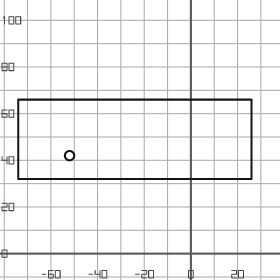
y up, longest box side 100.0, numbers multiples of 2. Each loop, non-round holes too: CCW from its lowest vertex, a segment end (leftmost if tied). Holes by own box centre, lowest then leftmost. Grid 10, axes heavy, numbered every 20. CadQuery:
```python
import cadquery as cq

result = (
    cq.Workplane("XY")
    .moveTo(-74.0, 32.0)
    .lineTo(26.0, 32.0)
    .lineTo(26.0, 66.0)
    .lineTo(-74.0, 66.0)
    .close()
    .moveTo(-52.0, 42.0)
    .circle(2.0)
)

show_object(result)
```